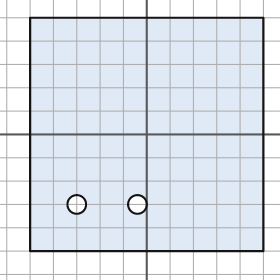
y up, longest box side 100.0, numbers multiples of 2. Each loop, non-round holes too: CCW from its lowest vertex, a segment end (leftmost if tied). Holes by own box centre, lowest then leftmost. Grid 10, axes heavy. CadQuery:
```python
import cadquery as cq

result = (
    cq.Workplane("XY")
    .moveTo(-50.0, -50.0)
    .lineTo(50.0, -50.0)
    .lineTo(50.0, 50.0)
    .lineTo(-50.0, 50.0)
    .close()
    .moveTo(-30.0, -30.0)
    .circle(4.0)
    .moveTo(-4.0, -30.0)
    .circle(4.0)
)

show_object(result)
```